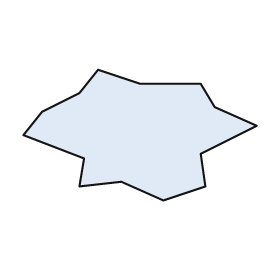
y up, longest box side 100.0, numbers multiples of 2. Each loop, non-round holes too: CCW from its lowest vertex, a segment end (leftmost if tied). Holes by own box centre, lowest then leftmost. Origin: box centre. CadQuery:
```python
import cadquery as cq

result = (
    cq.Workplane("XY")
    .moveTo(10.0, -28.0)
    .lineTo(28.0, -22.0)
    .lineTo(26.0, -8.0)
    .lineTo(50.0, 4.0)
    .lineTo(32.0, 12.0)
    .lineTo(26.0, 22.0)
    .lineTo(0.0, 22.0)
    .lineTo(-18.0, 28.0)
    .lineTo(-26.0, 18.0)
    .lineTo(-42.0, 10.0)
    .lineTo(-50.0, 0.0)
    .lineTo(-24.0, -10.0)
    .lineTo(-26.0, -22.0)
    .lineTo(-8.0, -20.0)
    .close()
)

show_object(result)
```